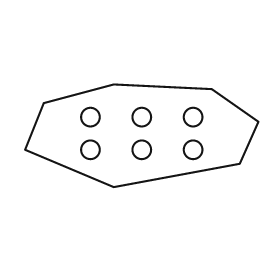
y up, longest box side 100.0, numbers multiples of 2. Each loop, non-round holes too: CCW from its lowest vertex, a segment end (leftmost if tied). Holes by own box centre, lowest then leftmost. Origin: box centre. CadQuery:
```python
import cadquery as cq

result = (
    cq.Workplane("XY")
    .moveTo(-12.0, -22.0)
    .lineTo(42.0, -12.0)
    .lineTo(50.0, 6.0)
    .lineTo(30.0, 20.0)
    .lineTo(-12.0, 22.0)
    .lineTo(-42.0, 14.0)
    .lineTo(-50.0, -6.0)
    .close()
    .moveTo(-22.0, -6.0)
    .circle(4.0)
    .moveTo(0.0, -6.0)
    .circle(4.0)
    .moveTo(22.0, -6.0)
    .circle(4.0)
    .moveTo(-22.0, 8.0)
    .circle(4.0)
    .moveTo(0.0, 8.0)
    .circle(4.0)
    .moveTo(22.0, 8.0)
    .circle(4.0)
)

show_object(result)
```